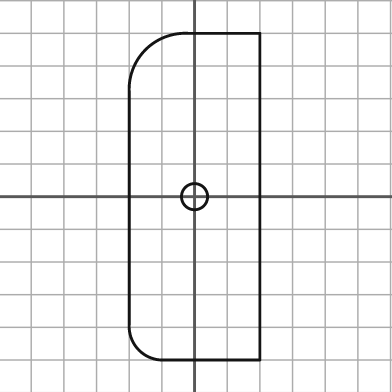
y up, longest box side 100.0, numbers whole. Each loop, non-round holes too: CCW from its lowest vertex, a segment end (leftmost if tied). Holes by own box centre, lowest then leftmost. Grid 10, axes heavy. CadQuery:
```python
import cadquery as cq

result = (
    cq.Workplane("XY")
    .moveTo(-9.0, -50.0)
    .lineTo(20.0, -50.0)
    .lineTo(20.0, 50.0)
    .lineTo(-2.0, 50.0)
    .threePointArc((-15.0, 45.0), (-20.0, 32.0))
    .lineTo(-20.0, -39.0)
    .threePointArc((-17.0, -47.0), (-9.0, -50.0))
    .close()
    .moveTo(0.0, 0.0)
    .circle(4.0)
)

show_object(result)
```